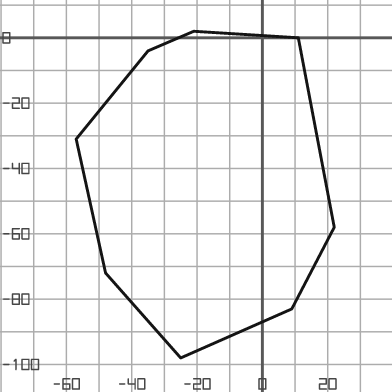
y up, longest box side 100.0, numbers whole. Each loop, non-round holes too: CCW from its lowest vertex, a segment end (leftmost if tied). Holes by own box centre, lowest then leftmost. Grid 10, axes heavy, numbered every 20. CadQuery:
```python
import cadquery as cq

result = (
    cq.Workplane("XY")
    .moveTo(-25.0, -98.0)
    .lineTo(9.0, -83.0)
    .lineTo(22.0, -58.0)
    .lineTo(11.0, 0.0)
    .lineTo(-21.0, 2.0)
    .lineTo(-35.0, -4.0)
    .lineTo(-57.0, -31.0)
    .lineTo(-48.0, -72.0)
    .close()
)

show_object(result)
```